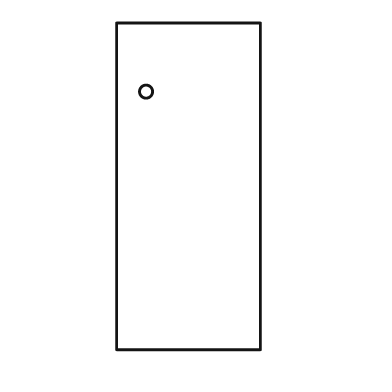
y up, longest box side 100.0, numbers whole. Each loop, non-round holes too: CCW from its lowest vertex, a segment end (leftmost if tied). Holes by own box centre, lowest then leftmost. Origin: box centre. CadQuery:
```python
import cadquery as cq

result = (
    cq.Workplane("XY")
    .moveTo(-22.0, -50.0)
    .lineTo(22.0, -50.0)
    .lineTo(22.0, 50.0)
    .lineTo(-22.0, 50.0)
    .close()
    .moveTo(-13.0, 29.0)
    .circle(2.0)
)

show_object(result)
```